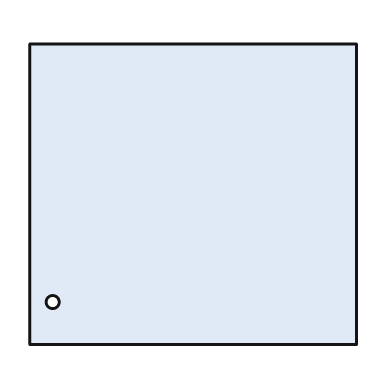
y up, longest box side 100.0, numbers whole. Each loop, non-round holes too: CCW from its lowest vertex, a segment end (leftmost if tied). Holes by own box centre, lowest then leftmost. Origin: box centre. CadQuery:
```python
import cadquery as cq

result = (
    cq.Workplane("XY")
    .moveTo(-50.0, -46.0)
    .lineTo(50.0, -46.0)
    .lineTo(50.0, 46.0)
    .lineTo(-50.0, 46.0)
    .close()
    .moveTo(-43.0, -33.0)
    .circle(2.0)
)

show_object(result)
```